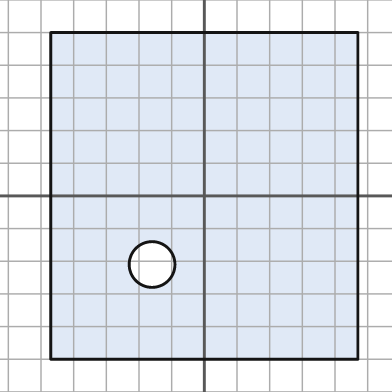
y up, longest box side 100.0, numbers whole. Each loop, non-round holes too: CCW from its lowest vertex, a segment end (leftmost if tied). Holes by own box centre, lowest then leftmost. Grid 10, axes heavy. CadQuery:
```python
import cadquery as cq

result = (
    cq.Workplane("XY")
    .moveTo(-47.0, -50.0)
    .lineTo(47.0, -50.0)
    .lineTo(47.0, 50.0)
    .lineTo(-47.0, 50.0)
    .close()
    .moveTo(-16.0, -21.0)
    .circle(7.0)
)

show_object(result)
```